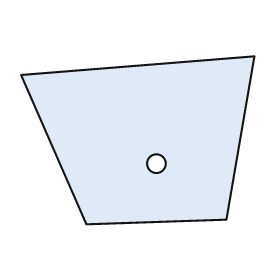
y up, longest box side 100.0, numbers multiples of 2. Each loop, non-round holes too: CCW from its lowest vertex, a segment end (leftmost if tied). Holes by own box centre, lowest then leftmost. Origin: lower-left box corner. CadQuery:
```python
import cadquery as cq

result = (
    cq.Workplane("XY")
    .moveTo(28.0, 0.0)
    .lineTo(88.0, 2.0)
    .lineTo(100.0, 72.0)
    .lineTo(0.0, 64.0)
    .close()
    .moveTo(58.0, 26.0)
    .circle(4.0)
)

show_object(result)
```